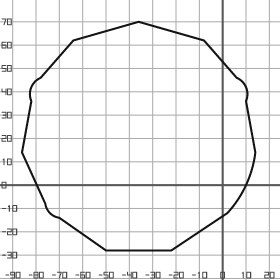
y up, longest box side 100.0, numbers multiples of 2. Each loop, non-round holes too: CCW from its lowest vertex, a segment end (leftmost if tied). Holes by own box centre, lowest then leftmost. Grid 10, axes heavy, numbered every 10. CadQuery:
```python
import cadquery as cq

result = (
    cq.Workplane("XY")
    .moveTo(-50.0, -28.0)
    .lineTo(-22.0, -28.0)
    .lineTo(2.0, -12.0)
    .threePointArc((10.0, 0.0), (14.0, 14.0))
    .lineTo(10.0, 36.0)
    .threePointArc((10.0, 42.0), (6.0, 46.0))
    .lineTo(-8.0, 62.0)
    .lineTo(-36.0, 70.0)
    .lineTo(-64.0, 62.0)
    .lineTo(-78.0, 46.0)
    .threePointArc((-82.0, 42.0), (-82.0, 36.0))
    .lineTo(-86.0, 14.0)
    .lineTo(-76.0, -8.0)
    .threePointArc((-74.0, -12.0), (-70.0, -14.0))
    .close()
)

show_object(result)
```